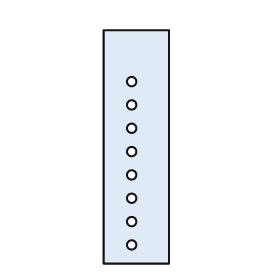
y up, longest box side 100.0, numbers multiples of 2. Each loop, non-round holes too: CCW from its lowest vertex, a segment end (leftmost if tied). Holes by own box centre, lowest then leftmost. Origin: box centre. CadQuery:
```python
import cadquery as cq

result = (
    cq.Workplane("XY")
    .moveTo(-14.0, -50.0)
    .lineTo(14.0, -50.0)
    .lineTo(14.0, 50.0)
    .lineTo(-14.0, 50.0)
    .close()
    .moveTo(-2.0, -42.0)
    .circle(2.0)
    .moveTo(-2.0, -32.0)
    .circle(2.0)
    .moveTo(-2.0, -22.0)
    .circle(2.0)
    .moveTo(-2.0, -12.0)
    .circle(2.0)
    .moveTo(-2.0, -2.0)
    .circle(2.0)
    .moveTo(-2.0, 8.0)
    .circle(2.0)
    .moveTo(-2.0, 18.0)
    .circle(2.0)
    .moveTo(-2.0, 28.0)
    .circle(2.0)
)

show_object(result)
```